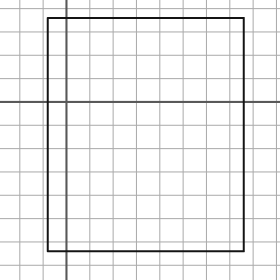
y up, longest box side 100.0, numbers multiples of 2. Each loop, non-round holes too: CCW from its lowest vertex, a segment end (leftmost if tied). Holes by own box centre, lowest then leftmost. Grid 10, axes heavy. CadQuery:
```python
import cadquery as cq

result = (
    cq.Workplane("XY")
    .moveTo(-8.0, -64.0)
    .lineTo(76.0, -64.0)
    .lineTo(76.0, 36.0)
    .lineTo(-8.0, 36.0)
    .close()
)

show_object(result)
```